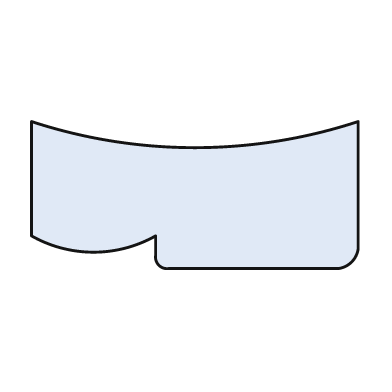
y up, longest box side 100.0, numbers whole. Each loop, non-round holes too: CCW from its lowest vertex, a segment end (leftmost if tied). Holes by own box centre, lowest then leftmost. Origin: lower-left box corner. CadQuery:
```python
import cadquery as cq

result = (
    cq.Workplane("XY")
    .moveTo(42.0, 0.0)
    .lineTo(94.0, 0.0)
    .threePointArc((98.0, 2.0), (100.0, 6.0))
    .lineTo(100.0, 45.0)
    .threePointArc((50.0, 37.0), (0.0, 45.0))
    .lineTo(0.0, 10.0)
    .threePointArc((19.0, 5.0), (38.0, 10.0))
    .lineTo(38.0, 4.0)
    .threePointArc((39.0, 1.0), (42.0, 0.0))
    .close()
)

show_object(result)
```